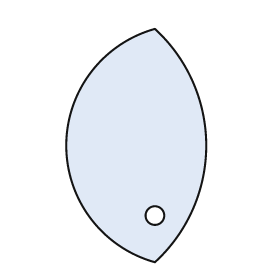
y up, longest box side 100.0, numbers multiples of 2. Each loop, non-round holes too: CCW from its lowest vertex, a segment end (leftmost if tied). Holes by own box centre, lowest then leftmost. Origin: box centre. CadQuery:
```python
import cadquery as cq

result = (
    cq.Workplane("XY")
    .moveTo(8.0, -50.0)
    .threePointArc((30.0, 0.0), (8.0, 50.0))
    .threePointArc((-30.0, 0.0), (8.0, -50.0))
    .close()
    .moveTo(8.0, -30.0)
    .circle(4.0)
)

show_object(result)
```